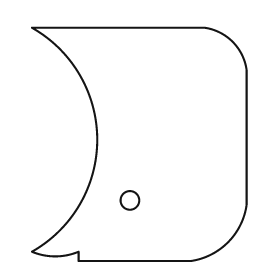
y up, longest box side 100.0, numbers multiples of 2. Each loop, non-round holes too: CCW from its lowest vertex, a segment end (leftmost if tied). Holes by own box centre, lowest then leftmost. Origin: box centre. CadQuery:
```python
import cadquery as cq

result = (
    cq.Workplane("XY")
    .moveTo(-26.0, -50.0)
    .lineTo(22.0, -50.0)
    .threePointArc((38.0, -42.0), (46.0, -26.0))
    .lineTo(46.0, 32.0)
    .threePointArc((40.0, 44.0), (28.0, 50.0))
    .lineTo(-46.0, 50.0)
    .threePointArc((-18.0, 2.0), (-46.0, -46.0))
    .threePointArc((-36.0, -48.0), (-26.0, -46.0))
    .close()
    .moveTo(-4.0, -24.0)
    .circle(4.0)
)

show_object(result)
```